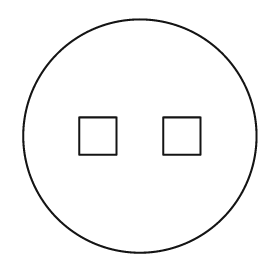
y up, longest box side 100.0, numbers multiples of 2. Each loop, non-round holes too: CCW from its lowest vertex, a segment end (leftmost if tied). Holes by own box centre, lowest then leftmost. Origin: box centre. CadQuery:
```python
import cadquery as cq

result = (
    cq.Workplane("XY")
    .moveTo(0.0, 0.0)
    .circle(50.0)
    .moveTo(-26.0, -8.0)
    .lineTo(-10.0, -8.0)
    .lineTo(-10.0, 8.0)
    .lineTo(-26.0, 8.0)
    .close()
    .moveTo(10.0, -8.0)
    .lineTo(26.0, -8.0)
    .lineTo(26.0, 8.0)
    .lineTo(10.0, 8.0)
    .close()
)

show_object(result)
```